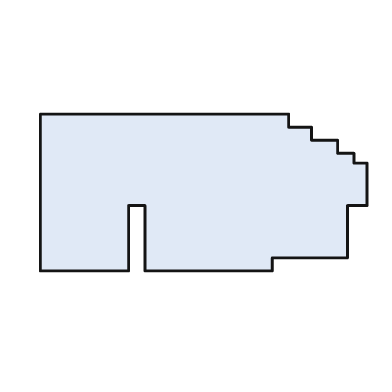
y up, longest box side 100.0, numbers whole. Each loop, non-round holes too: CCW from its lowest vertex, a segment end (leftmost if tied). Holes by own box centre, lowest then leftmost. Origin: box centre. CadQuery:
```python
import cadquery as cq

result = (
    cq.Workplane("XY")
    .moveTo(-50.0, -24.0)
    .lineTo(-23.0, -24.0)
    .lineTo(-23.0, -4.0)
    .lineTo(-18.0, -4.0)
    .lineTo(-18.0, -24.0)
    .lineTo(21.0, -24.0)
    .lineTo(21.0, -20.0)
    .lineTo(44.0, -20.0)
    .lineTo(44.0, -4.0)
    .lineTo(50.0, -4.0)
    .lineTo(50.0, 9.0)
    .lineTo(46.0, 9.0)
    .lineTo(46.0, 12.0)
    .lineTo(41.0, 12.0)
    .lineTo(41.0, 16.0)
    .lineTo(33.0, 16.0)
    .lineTo(33.0, 20.0)
    .lineTo(26.0, 20.0)
    .lineTo(26.0, 24.0)
    .lineTo(-50.0, 24.0)
    .close()
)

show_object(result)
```